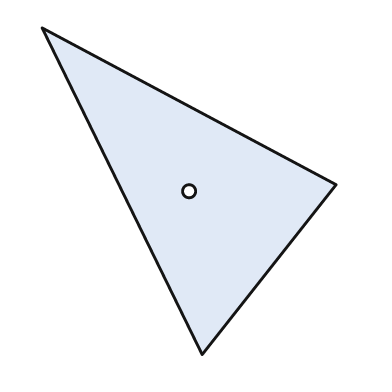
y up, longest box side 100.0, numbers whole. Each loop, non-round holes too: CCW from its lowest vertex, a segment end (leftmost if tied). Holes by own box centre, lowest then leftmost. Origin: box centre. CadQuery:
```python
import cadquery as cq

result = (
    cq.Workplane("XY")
    .moveTo(4.0, -50.0)
    .lineTo(45.0, 2.0)
    .lineTo(-45.0, 50.0)
    .close()
    .moveTo(0.0, 0.0)
    .circle(2.0)
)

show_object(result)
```